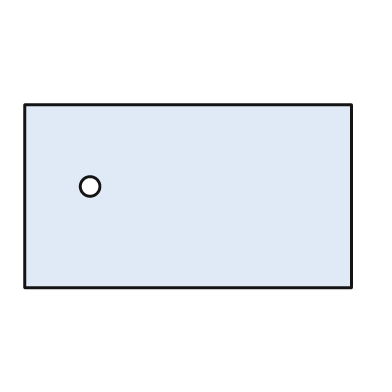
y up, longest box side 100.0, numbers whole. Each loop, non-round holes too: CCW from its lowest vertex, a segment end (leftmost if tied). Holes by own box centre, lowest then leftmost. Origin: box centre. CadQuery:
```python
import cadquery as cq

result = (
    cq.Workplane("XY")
    .moveTo(-50.0, -28.0)
    .lineTo(50.0, -28.0)
    .lineTo(50.0, 28.0)
    .lineTo(-50.0, 28.0)
    .close()
    .moveTo(-30.0, 3.0)
    .circle(3.0)
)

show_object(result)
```